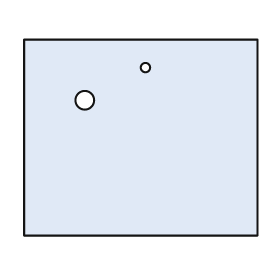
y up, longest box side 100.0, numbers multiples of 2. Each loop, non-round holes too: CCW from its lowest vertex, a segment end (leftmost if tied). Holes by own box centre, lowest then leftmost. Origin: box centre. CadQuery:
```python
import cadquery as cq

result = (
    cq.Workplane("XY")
    .moveTo(-50.0, -42.0)
    .lineTo(50.0, -42.0)
    .lineTo(50.0, 42.0)
    .lineTo(-50.0, 42.0)
    .close()
    .moveTo(-24.0, 16.0)
    .circle(4.0)
    .moveTo(2.0, 30.0)
    .circle(2.0)
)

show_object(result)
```